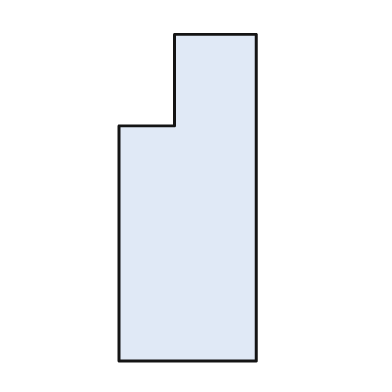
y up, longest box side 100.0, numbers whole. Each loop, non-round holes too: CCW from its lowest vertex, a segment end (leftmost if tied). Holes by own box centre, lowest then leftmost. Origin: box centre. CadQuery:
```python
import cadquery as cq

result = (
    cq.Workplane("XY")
    .moveTo(-21.0, -50.0)
    .lineTo(21.0, -50.0)
    .lineTo(21.0, 50.0)
    .lineTo(-4.0, 50.0)
    .lineTo(-4.0, 22.0)
    .lineTo(-21.0, 22.0)
    .close()
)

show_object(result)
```